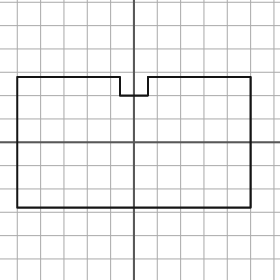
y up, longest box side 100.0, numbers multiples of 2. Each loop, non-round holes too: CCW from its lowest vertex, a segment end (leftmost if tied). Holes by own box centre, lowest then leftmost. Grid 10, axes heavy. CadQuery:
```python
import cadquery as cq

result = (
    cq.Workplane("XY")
    .moveTo(-50.0, -28.0)
    .lineTo(50.0, -28.0)
    .lineTo(50.0, 28.0)
    .lineTo(6.0, 28.0)
    .lineTo(6.0, 20.0)
    .lineTo(-6.0, 20.0)
    .lineTo(-6.0, 28.0)
    .lineTo(-50.0, 28.0)
    .close()
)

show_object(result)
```